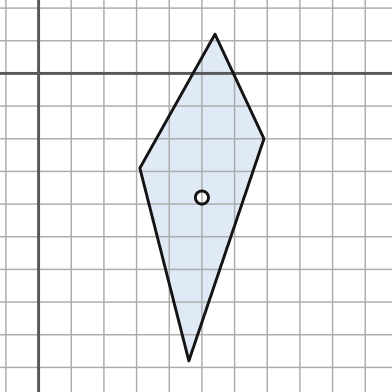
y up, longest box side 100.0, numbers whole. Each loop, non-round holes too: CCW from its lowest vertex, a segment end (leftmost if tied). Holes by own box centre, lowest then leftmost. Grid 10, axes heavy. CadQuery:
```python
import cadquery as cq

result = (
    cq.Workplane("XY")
    .moveTo(46.0, -88.0)
    .lineTo(69.0, -20.0)
    .lineTo(54.0, 12.0)
    .lineTo(31.0, -29.0)
    .close()
    .moveTo(50.0, -38.0)
    .circle(2.0)
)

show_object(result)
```